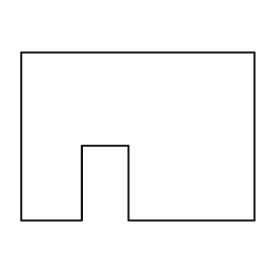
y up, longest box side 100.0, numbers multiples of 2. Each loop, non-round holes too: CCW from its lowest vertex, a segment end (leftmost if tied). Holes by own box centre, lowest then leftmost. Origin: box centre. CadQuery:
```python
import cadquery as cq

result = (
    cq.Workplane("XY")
    .moveTo(-50.0, -36.0)
    .lineTo(-24.0, -36.0)
    .lineTo(-24.0, -4.0)
    .lineTo(-4.0, -4.0)
    .lineTo(-4.0, -36.0)
    .lineTo(50.0, -36.0)
    .lineTo(50.0, 36.0)
    .lineTo(-50.0, 36.0)
    .close()
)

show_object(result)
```